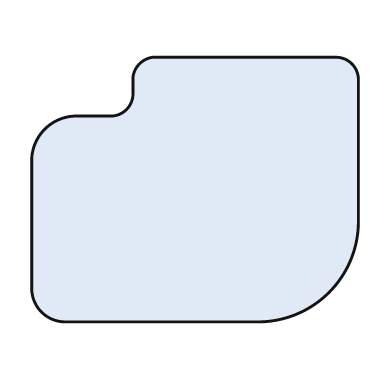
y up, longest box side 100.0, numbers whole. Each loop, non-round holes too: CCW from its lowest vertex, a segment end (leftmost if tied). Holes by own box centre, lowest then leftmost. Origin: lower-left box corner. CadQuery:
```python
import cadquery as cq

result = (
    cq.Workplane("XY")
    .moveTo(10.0, 0.0)
    .lineTo(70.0, 0.0)
    .threePointArc((91.0, 9.0), (100.0, 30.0))
    .lineTo(100.0, 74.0)
    .threePointArc((98.0, 79.0), (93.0, 81.0))
    .lineTo(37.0, 81.0)
    .threePointArc((33.0, 79.0), (31.0, 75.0))
    .lineTo(31.0, 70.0)
    .threePointArc((29.0, 65.0), (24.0, 63.0))
    .lineTo(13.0, 63.0)
    .threePointArc((4.0, 59.0), (0.0, 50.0))
    .lineTo(0.0, 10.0)
    .threePointArc((3.0, 3.0), (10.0, 0.0))
    .close()
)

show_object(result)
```